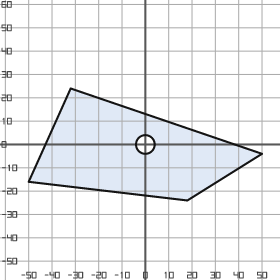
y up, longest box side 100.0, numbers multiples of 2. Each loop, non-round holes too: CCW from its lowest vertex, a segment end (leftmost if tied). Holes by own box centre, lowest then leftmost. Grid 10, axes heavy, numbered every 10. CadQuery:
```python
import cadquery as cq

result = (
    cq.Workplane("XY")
    .moveTo(18.0, -24.0)
    .lineTo(50.0, -4.0)
    .lineTo(-32.0, 24.0)
    .lineTo(-50.0, -16.0)
    .close()
    .moveTo(0.0, 0.0)
    .circle(4.0)
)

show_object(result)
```